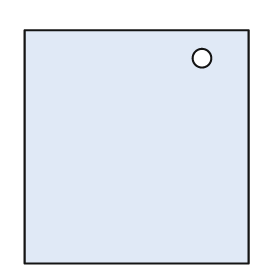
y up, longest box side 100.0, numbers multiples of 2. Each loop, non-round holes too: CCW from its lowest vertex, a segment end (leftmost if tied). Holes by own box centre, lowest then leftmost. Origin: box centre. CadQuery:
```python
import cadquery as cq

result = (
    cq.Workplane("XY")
    .moveTo(-48.0, -50.0)
    .lineTo(48.0, -50.0)
    .lineTo(48.0, 50.0)
    .lineTo(-48.0, 50.0)
    .close()
    .moveTo(28.0, 38.0)
    .circle(4.0)
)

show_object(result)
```